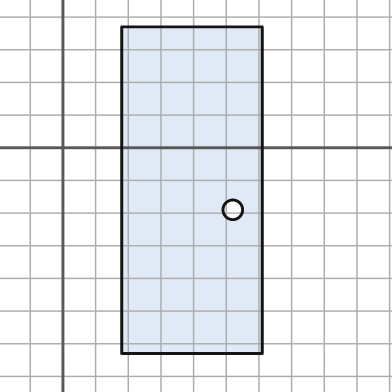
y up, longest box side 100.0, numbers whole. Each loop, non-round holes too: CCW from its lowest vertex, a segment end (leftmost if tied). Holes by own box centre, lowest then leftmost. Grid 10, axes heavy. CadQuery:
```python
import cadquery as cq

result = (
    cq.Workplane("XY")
    .moveTo(18.0, -63.0)
    .lineTo(61.0, -63.0)
    .lineTo(61.0, 37.0)
    .lineTo(18.0, 37.0)
    .close()
    .moveTo(52.0, -19.0)
    .circle(3.0)
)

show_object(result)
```